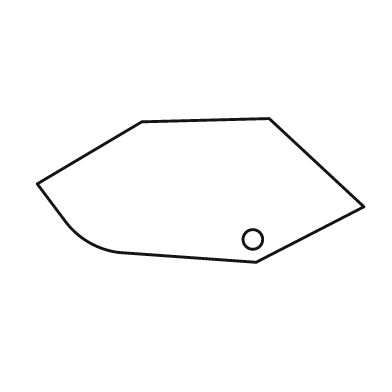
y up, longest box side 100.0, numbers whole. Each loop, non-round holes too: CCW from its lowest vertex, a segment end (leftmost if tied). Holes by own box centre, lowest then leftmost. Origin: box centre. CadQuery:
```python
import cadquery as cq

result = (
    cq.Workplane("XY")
    .moveTo(17.0, -22.0)
    .lineTo(50.0, -5.0)
    .lineTo(21.0, 22.0)
    .lineTo(-18.0, 21.0)
    .lineTo(-50.0, 2.0)
    .lineTo(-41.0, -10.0)
    .threePointArc((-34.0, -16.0), (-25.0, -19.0))
    .close()
    .moveTo(16.0, -15.0)
    .circle(3.0)
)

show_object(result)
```